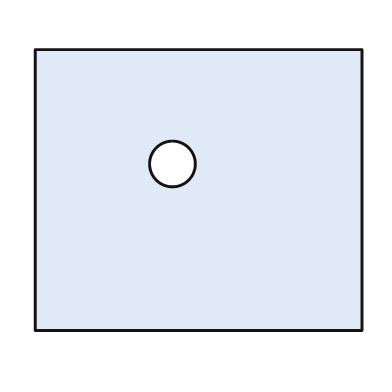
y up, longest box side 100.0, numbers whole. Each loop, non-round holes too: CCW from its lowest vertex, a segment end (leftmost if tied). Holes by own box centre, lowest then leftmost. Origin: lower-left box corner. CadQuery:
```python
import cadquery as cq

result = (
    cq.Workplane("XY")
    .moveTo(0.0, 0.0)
    .lineTo(100.0, 0.0)
    .lineTo(100.0, 86.0)
    .lineTo(0.0, 86.0)
    .close()
    .moveTo(42.0, 51.0)
    .circle(7.0)
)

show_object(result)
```